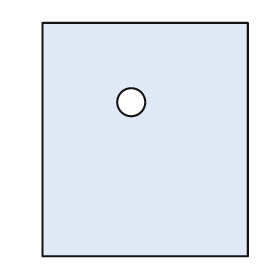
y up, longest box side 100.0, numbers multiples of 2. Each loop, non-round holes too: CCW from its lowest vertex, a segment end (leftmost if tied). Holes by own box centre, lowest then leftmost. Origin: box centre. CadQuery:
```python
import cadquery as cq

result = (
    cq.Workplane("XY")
    .moveTo(-44.0, -50.0)
    .lineTo(44.0, -50.0)
    .lineTo(44.0, 50.0)
    .lineTo(-44.0, 50.0)
    .close()
    .moveTo(-6.0, 16.0)
    .circle(6.0)
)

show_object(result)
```